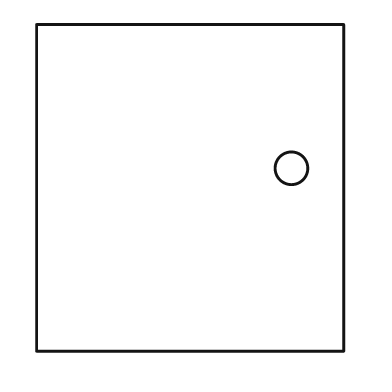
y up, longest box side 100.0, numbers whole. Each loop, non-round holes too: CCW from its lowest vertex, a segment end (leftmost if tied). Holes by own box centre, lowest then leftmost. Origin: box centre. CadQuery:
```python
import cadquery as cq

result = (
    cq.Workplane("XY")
    .moveTo(-47.0, -50.0)
    .lineTo(47.0, -50.0)
    .lineTo(47.0, 50.0)
    .lineTo(-47.0, 50.0)
    .close()
    .moveTo(31.0, 6.0)
    .circle(5.0)
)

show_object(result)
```